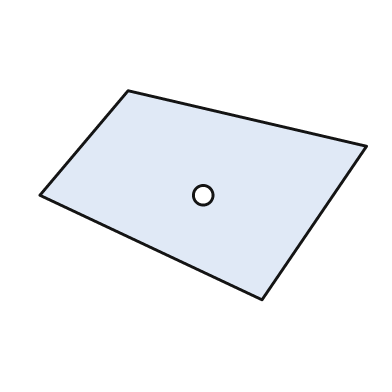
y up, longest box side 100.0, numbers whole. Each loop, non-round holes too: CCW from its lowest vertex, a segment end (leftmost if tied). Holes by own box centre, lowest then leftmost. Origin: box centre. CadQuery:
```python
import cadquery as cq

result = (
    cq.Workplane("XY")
    .moveTo(18.0, -32.0)
    .lineTo(50.0, 15.0)
    .lineTo(-23.0, 32.0)
    .lineTo(-50.0, 0.0)
    .close()
    .moveTo(0.0, 0.0)
    .circle(3.0)
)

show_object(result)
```